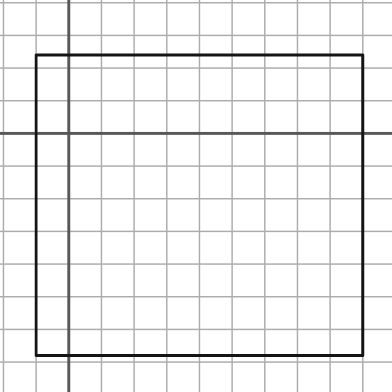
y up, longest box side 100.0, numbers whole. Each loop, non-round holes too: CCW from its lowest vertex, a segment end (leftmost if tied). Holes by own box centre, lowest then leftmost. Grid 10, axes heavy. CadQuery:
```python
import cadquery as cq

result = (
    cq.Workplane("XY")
    .moveTo(-10.0, -68.0)
    .lineTo(90.0, -68.0)
    .lineTo(90.0, 24.0)
    .lineTo(-10.0, 24.0)
    .close()
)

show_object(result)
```